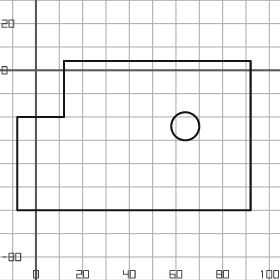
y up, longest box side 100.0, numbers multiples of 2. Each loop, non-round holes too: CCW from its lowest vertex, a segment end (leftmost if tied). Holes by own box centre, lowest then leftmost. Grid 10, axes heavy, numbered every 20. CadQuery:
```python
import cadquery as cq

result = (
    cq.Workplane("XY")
    .moveTo(-8.0, -60.0)
    .lineTo(92.0, -60.0)
    .lineTo(92.0, 4.0)
    .lineTo(12.0, 4.0)
    .lineTo(12.0, -20.0)
    .lineTo(-8.0, -20.0)
    .close()
    .moveTo(64.0, -24.0)
    .circle(6.0)
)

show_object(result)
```